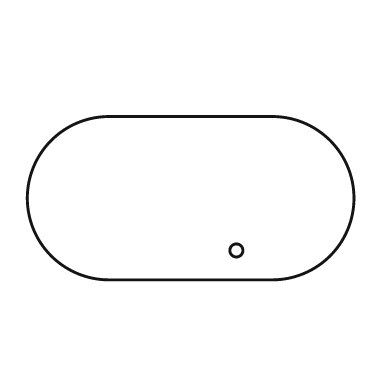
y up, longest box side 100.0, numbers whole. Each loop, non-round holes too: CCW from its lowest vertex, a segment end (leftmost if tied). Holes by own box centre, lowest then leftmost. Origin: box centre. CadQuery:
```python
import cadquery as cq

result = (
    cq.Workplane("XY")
    .moveTo(-25.0, -25.0)
    .lineTo(25.0, -25.0)
    .threePointArc((50.0, 0.0), (25.0, 25.0))
    .lineTo(-25.0, 25.0)
    .threePointArc((-50.0, 0.0), (-25.0, -25.0))
    .close()
    .moveTo(14.0, -16.0)
    .circle(2.0)
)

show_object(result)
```